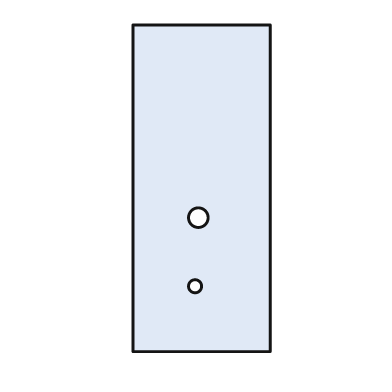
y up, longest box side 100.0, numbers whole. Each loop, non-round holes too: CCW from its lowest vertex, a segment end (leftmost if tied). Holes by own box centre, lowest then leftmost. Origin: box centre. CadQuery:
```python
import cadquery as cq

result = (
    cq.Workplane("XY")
    .moveTo(-21.0, -50.0)
    .lineTo(21.0, -50.0)
    .lineTo(21.0, 50.0)
    .lineTo(-21.0, 50.0)
    .close()
    .moveTo(-2.0, -30.0)
    .circle(2.0)
    .moveTo(-1.0, -9.0)
    .circle(3.0)
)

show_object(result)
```